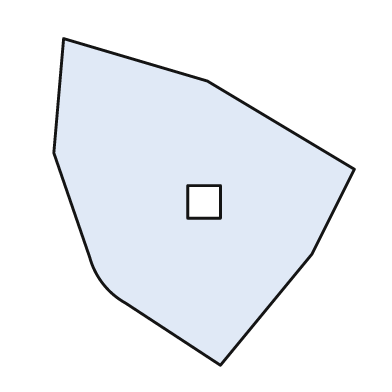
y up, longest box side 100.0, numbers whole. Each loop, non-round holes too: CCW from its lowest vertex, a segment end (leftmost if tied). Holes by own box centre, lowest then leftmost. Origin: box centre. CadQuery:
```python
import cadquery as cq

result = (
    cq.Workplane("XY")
    .moveTo(5.0, -50.0)
    .lineTo(33.0, -16.0)
    .lineTo(46.0, 10.0)
    .lineTo(1.0, 37.0)
    .lineTo(-43.0, 50.0)
    .lineTo(-46.0, 15.0)
    .lineTo(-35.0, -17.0)
    .threePointArc((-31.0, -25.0), (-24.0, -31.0))
    .close()
    .moveTo(-5.0, -5.0)
    .lineTo(5.0, -5.0)
    .lineTo(5.0, 5.0)
    .lineTo(-5.0, 5.0)
    .close()
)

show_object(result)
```